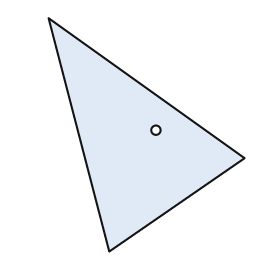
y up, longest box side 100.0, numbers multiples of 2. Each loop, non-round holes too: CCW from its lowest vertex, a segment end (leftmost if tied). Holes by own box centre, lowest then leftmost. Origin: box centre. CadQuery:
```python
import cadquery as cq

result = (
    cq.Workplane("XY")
    .moveTo(-16.0, -50.0)
    .lineTo(42.0, -10.0)
    .lineTo(-42.0, 50.0)
    .close()
    .moveTo(4.0, 2.0)
    .circle(2.0)
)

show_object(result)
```